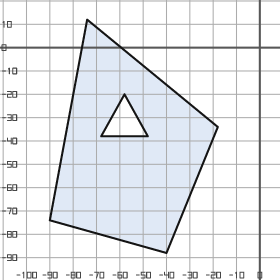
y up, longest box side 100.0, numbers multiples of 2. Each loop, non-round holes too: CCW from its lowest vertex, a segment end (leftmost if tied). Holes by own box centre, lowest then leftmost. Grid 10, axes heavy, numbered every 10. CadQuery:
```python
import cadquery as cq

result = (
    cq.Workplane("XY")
    .moveTo(-40.0, -88.0)
    .lineTo(-18.0, -34.0)
    .lineTo(-74.0, 12.0)
    .lineTo(-90.0, -74.0)
    .close()
    .moveTo(-68.0, -38.0)
    .lineTo(-48.0, -38.0)
    .lineTo(-58.0, -20.0)
    .close()
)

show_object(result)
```